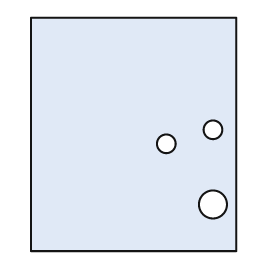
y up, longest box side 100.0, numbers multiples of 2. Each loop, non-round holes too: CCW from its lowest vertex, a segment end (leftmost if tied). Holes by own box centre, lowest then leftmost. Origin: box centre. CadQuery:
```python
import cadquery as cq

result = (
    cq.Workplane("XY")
    .moveTo(-44.0, -50.0)
    .lineTo(44.0, -50.0)
    .lineTo(44.0, 50.0)
    .lineTo(-44.0, 50.0)
    .close()
    .moveTo(34.0, -30.0)
    .circle(6.0)
    .moveTo(14.0, -4.0)
    .circle(4.0)
    .moveTo(34.0, 2.0)
    .circle(4.0)
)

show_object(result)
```